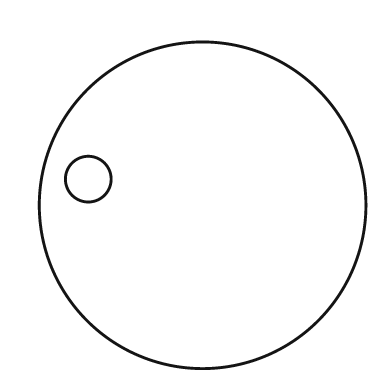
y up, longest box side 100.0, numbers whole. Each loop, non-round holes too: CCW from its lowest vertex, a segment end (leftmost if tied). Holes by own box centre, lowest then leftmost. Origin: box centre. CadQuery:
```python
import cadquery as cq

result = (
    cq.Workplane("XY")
    .moveTo(0.0, 0.0)
    .circle(50.0)
    .moveTo(-35.0, 8.0)
    .circle(7.0)
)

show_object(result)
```